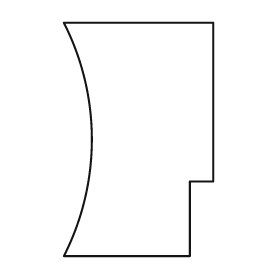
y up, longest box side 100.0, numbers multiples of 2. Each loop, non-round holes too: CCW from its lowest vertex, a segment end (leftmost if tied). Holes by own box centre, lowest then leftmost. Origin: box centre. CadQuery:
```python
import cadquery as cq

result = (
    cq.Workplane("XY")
    .moveTo(-32.0, -50.0)
    .lineTo(22.0, -50.0)
    .lineTo(22.0, -18.0)
    .lineTo(32.0, -18.0)
    .lineTo(32.0, 50.0)
    .lineTo(-32.0, 50.0)
    .threePointArc((-20.0, 0.0), (-32.0, -50.0))
    .close()
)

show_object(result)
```